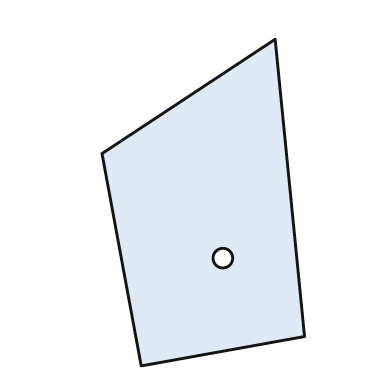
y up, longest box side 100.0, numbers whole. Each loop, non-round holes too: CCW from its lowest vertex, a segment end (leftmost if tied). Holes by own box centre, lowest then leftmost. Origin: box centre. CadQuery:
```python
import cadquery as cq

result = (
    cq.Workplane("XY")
    .moveTo(-19.0, -50.0)
    .lineTo(31.0, -41.0)
    .lineTo(22.0, 50.0)
    .lineTo(-31.0, 15.0)
    .close()
    .moveTo(6.0, -17.0)
    .circle(3.0)
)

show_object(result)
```